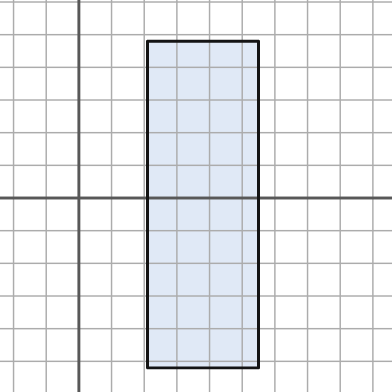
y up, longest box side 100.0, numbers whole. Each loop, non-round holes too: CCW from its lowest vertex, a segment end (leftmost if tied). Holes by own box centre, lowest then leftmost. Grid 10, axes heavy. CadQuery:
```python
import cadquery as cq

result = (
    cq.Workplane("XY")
    .moveTo(21.0, -52.0)
    .lineTo(55.0, -52.0)
    .lineTo(55.0, 48.0)
    .lineTo(21.0, 48.0)
    .close()
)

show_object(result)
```